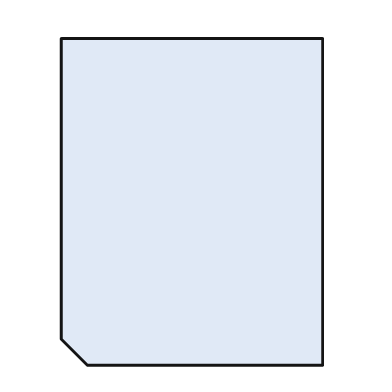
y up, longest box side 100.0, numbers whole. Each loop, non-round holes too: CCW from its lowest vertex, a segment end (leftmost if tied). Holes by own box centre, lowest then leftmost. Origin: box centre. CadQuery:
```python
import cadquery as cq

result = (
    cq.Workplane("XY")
    .moveTo(-32.0, -50.0)
    .lineTo(40.0, -50.0)
    .lineTo(40.0, 50.0)
    .lineTo(-40.0, 50.0)
    .lineTo(-40.0, -42.0)
    .close()
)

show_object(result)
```